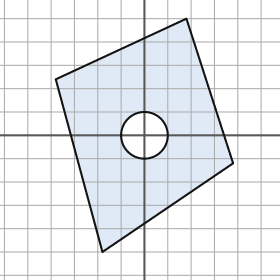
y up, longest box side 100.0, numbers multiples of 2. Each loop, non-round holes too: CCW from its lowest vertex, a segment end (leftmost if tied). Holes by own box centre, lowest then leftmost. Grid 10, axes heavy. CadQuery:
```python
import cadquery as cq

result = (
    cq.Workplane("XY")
    .moveTo(-18.0, -50.0)
    .lineTo(38.0, -12.0)
    .lineTo(18.0, 50.0)
    .lineTo(-38.0, 24.0)
    .close()
    .moveTo(0.0, 0.0)
    .circle(10.0)
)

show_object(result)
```